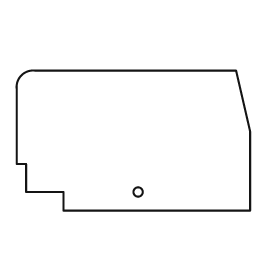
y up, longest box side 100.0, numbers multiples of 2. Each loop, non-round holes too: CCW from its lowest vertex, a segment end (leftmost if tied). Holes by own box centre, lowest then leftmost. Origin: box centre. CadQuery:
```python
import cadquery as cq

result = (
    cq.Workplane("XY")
    .moveTo(-30.0, -30.0)
    .lineTo(50.0, -30.0)
    .lineTo(50.0, 4.0)
    .lineTo(44.0, 30.0)
    .lineTo(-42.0, 30.0)
    .threePointArc((-48.0, 28.0), (-50.0, 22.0))
    .lineTo(-50.0, -10.0)
    .lineTo(-46.0, -10.0)
    .lineTo(-46.0, -22.0)
    .lineTo(-30.0, -22.0)
    .close()
    .moveTo(2.0, -22.0)
    .circle(2.0)
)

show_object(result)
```